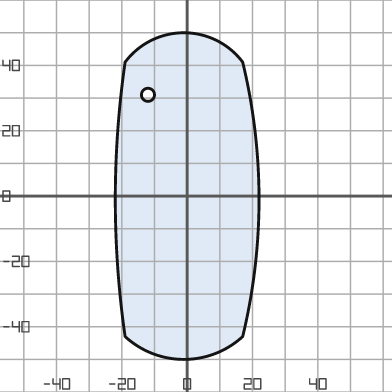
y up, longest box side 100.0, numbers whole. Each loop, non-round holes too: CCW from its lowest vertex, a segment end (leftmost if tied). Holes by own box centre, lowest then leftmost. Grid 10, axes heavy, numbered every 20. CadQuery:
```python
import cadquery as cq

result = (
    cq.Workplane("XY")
    .moveTo(-19.0, -43.0)
    .threePointArc((-1.0, -50.0), (17.0, -43.0))
    .threePointArc((22.0, -1.0), (17.0, 41.0))
    .threePointArc((-1.0, 50.0), (-19.0, 41.0))
    .threePointArc((-22.0, -1.0), (-19.0, -43.0))
    .close()
    .moveTo(-12.0, 31.0)
    .circle(2.0)
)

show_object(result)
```